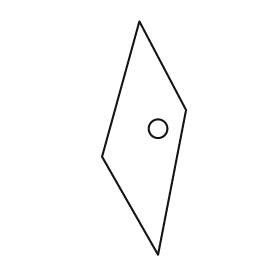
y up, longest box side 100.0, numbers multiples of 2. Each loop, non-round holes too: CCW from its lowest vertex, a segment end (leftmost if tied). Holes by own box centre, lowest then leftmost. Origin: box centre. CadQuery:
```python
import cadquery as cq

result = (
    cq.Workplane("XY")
    .moveTo(6.0, -50.0)
    .lineTo(18.0, 12.0)
    .lineTo(-2.0, 50.0)
    .lineTo(-18.0, -8.0)
    .close()
    .moveTo(6.0, 4.0)
    .circle(4.0)
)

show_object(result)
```